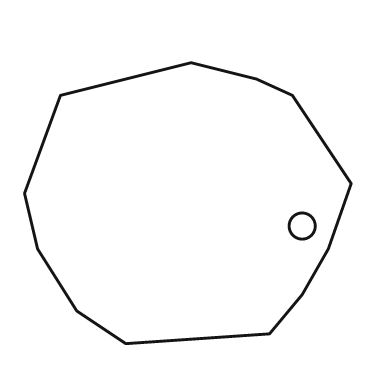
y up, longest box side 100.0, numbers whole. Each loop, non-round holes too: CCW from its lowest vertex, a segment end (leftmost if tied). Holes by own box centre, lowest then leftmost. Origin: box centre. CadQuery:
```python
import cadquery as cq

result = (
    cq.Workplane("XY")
    .moveTo(-19.0, -43.0)
    .lineTo(25.0, -40.0)
    .lineTo(35.0, -28.0)
    .lineTo(43.0, -14.0)
    .lineTo(50.0, 6.0)
    .lineTo(32.0, 33.0)
    .lineTo(21.0, 38.0)
    .lineTo(1.0, 43.0)
    .lineTo(-39.0, 33.0)
    .lineTo(-50.0, 3.0)
    .lineTo(-46.0, -14.0)
    .lineTo(-34.0, -33.0)
    .close()
    .moveTo(35.0, -7.0)
    .circle(4.0)
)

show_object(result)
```